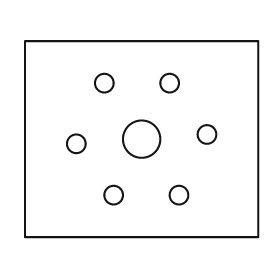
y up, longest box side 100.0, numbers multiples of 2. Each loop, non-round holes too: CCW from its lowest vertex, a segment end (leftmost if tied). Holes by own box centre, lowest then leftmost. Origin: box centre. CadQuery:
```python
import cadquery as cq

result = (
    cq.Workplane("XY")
    .moveTo(-50.0, -42.0)
    .lineTo(50.0, -42.0)
    .lineTo(50.0, 42.0)
    .lineTo(-50.0, 42.0)
    .close()
    .moveTo(-12.0, -24.0)
    .circle(4.0)
    .moveTo(16.0, -24.0)
    .circle(4.0)
    .moveTo(-28.0, -2.0)
    .circle(4.0)
    .moveTo(0.0, 0.0)
    .circle(8.0)
    .moveTo(28.0, 2.0)
    .circle(4.0)
    .moveTo(-16.0, 24.0)
    .circle(4.0)
    .moveTo(12.0, 24.0)
    .circle(4.0)
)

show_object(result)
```